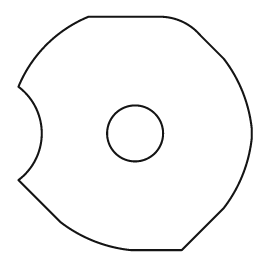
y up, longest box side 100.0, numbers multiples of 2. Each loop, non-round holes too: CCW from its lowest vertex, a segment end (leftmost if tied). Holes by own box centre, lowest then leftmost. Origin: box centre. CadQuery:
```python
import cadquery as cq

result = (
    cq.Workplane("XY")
    .moveTo(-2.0, -50.0)
    .lineTo(20.0, -50.0)
    .lineTo(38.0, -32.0)
    .threePointArc((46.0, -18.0), (50.0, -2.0))
    .lineTo(50.0, 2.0)
    .threePointArc((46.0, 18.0), (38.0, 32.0))
    .lineTo(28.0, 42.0)
    .threePointArc((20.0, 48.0), (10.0, 50.0))
    .lineTo(-20.0, 50.0)
    .threePointArc((-38.0, 38.0), (-50.0, 20.0))
    .threePointArc((-40.0, 0.0), (-50.0, -20.0))
    .lineTo(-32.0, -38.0)
    .threePointArc((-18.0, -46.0), (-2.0, -50.0))
    .close()
    .moveTo(0.0, 0.0)
    .circle(12.0)
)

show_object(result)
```